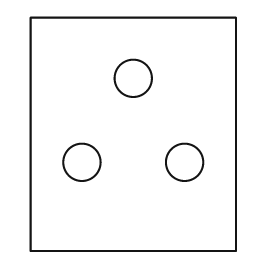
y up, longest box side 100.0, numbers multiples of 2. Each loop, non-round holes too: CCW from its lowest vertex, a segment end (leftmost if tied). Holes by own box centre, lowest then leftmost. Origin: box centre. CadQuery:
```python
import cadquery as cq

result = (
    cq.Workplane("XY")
    .moveTo(-44.0, -50.0)
    .lineTo(44.0, -50.0)
    .lineTo(44.0, 50.0)
    .lineTo(-44.0, 50.0)
    .close()
    .moveTo(-22.0, -12.0)
    .circle(8.0)
    .moveTo(22.0, -12.0)
    .circle(8.0)
    .moveTo(0.0, 24.0)
    .circle(8.0)
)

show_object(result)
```